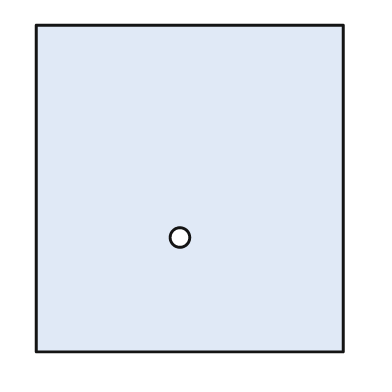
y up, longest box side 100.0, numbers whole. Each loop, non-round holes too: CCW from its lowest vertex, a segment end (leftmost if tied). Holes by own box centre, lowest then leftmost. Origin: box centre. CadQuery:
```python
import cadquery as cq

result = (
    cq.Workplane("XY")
    .moveTo(-47.0, -50.0)
    .lineTo(47.0, -50.0)
    .lineTo(47.0, 50.0)
    .lineTo(-47.0, 50.0)
    .close()
    .moveTo(-3.0, -15.0)
    .circle(3.0)
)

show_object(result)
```